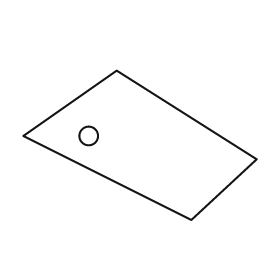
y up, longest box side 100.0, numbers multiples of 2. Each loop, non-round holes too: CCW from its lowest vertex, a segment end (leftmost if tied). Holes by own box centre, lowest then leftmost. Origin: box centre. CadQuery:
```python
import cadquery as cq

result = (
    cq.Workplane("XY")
    .moveTo(22.0, -32.0)
    .lineTo(50.0, -6.0)
    .lineTo(-10.0, 32.0)
    .lineTo(-50.0, 4.0)
    .close()
    .moveTo(-22.0, 4.0)
    .circle(4.0)
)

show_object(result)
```